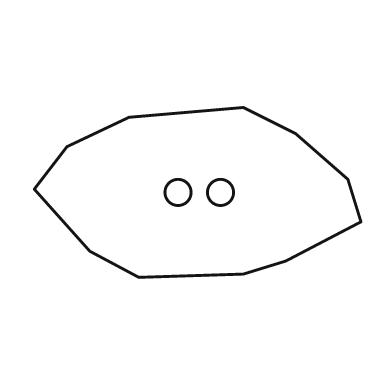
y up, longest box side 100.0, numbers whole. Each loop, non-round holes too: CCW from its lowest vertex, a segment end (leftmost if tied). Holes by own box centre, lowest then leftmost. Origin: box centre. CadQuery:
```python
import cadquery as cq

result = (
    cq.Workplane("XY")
    .moveTo(-18.0, -26.0)
    .lineTo(14.0, -25.0)
    .lineTo(27.0, -21.0)
    .lineTo(50.0, -9.0)
    .lineTo(46.0, 4.0)
    .lineTo(30.0, 18.0)
    .lineTo(14.0, 26.0)
    .lineTo(-21.0, 23.0)
    .lineTo(-40.0, 14.0)
    .lineTo(-50.0, 1.0)
    .lineTo(-33.0, -18.0)
    .close()
    .moveTo(-6.0, 0.0)
    .circle(4.0)
    .moveTo(7.0, 0.0)
    .circle(4.0)
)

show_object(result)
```